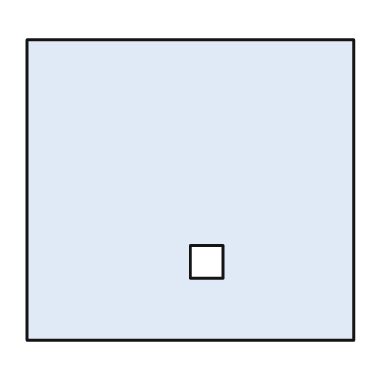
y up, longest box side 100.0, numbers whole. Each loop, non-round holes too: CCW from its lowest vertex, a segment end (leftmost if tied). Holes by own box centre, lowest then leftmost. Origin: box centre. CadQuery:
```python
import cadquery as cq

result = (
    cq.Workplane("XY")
    .moveTo(-50.0, -46.0)
    .lineTo(50.0, -46.0)
    .lineTo(50.0, 46.0)
    .lineTo(-50.0, 46.0)
    .close()
    .moveTo(0.0, -27.0)
    .lineTo(10.0, -27.0)
    .lineTo(10.0, -17.0)
    .lineTo(0.0, -17.0)
    .close()
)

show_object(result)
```